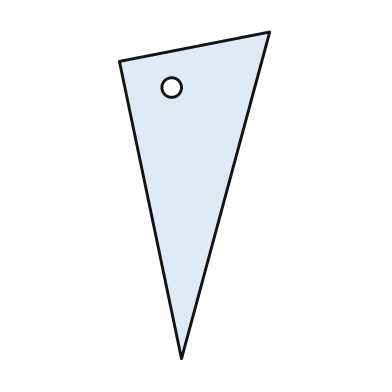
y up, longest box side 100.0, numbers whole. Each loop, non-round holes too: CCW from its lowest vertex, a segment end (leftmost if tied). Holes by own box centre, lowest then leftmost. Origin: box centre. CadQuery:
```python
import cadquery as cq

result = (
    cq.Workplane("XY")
    .moveTo(-4.0, -50.0)
    .lineTo(23.0, 50.0)
    .lineTo(-23.0, 41.0)
    .close()
    .moveTo(-7.0, 33.0)
    .circle(3.0)
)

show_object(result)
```